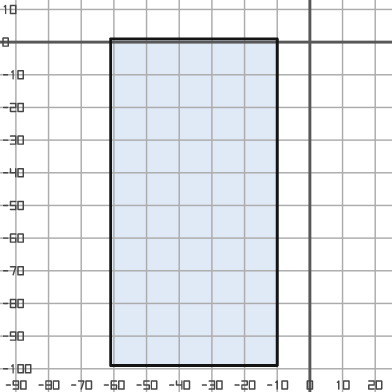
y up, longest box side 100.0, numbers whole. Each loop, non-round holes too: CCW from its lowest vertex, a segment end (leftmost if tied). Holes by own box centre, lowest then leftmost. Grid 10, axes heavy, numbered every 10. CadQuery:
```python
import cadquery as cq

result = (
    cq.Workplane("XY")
    .moveTo(-61.0, -99.0)
    .lineTo(-10.0, -99.0)
    .lineTo(-10.0, 1.0)
    .lineTo(-61.0, 1.0)
    .close()
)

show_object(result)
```